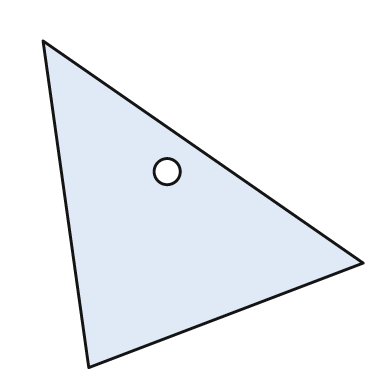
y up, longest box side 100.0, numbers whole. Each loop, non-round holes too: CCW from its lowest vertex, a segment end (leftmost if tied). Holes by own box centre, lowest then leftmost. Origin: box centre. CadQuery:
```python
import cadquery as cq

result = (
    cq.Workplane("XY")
    .moveTo(-35.0, -50.0)
    .lineTo(49.0, -18.0)
    .lineTo(-49.0, 50.0)
    .close()
    .moveTo(-11.0, 10.0)
    .circle(4.0)
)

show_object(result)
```